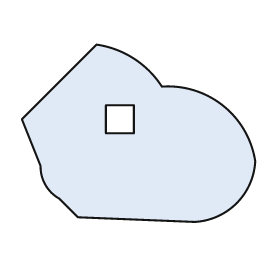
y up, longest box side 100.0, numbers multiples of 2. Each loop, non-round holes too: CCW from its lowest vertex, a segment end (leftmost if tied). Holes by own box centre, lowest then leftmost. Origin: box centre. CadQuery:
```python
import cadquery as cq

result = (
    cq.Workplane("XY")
    .moveTo(24.0, -38.0)
    .threePointArc((42.0, -30.0), (50.0, -12.0))
    .threePointArc((36.0, 12.0), (10.0, 20.0))
    .threePointArc((-2.0, 32.0), (-18.0, 38.0))
    .lineTo(-50.0, 6.0)
    .lineTo(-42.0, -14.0)
    .threePointArc((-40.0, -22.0), (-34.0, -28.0))
    .lineTo(-26.0, -36.0)
    .close()
    .moveTo(-14.0, 0.0)
    .lineTo(-2.0, 0.0)
    .lineTo(-2.0, 12.0)
    .lineTo(-14.0, 12.0)
    .close()
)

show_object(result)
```